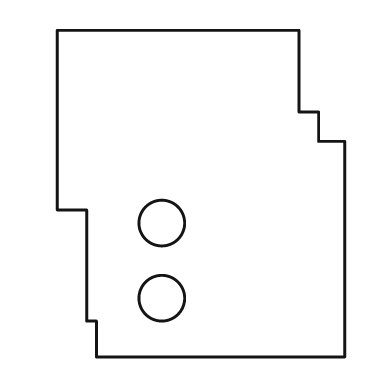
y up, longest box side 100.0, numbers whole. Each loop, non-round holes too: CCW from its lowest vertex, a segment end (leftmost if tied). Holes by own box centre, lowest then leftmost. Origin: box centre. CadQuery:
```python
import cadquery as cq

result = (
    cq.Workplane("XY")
    .moveTo(-32.0, -50.0)
    .lineTo(44.0, -50.0)
    .lineTo(44.0, 16.0)
    .lineTo(36.0, 16.0)
    .lineTo(36.0, 25.0)
    .lineTo(30.0, 25.0)
    .lineTo(30.0, 50.0)
    .lineTo(-44.0, 50.0)
    .lineTo(-44.0, -5.0)
    .lineTo(-35.0, -5.0)
    .lineTo(-35.0, -39.0)
    .lineTo(-32.0, -39.0)
    .close()
    .moveTo(-12.0, -32.0)
    .circle(7.0)
    .moveTo(-12.0, -9.0)
    .circle(7.0)
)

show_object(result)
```